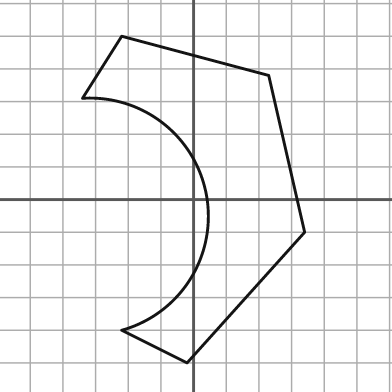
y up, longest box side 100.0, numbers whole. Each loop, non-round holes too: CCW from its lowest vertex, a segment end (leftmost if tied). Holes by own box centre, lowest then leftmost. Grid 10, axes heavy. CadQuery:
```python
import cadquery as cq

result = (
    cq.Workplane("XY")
    .moveTo(-2.0, -50.0)
    .lineTo(34.0, -10.0)
    .lineTo(23.0, 38.0)
    .lineTo(-22.0, 50.0)
    .lineTo(-34.0, 31.0)
    .threePointArc((4.0, 1.0), (-22.0, -40.0))
    .close()
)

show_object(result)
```